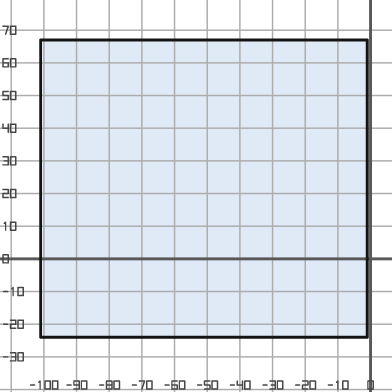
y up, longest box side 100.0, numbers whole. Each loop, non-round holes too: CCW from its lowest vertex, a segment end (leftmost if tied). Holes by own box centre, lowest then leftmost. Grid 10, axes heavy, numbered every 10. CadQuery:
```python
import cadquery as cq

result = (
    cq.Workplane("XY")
    .moveTo(-101.0, -24.0)
    .lineTo(-1.0, -24.0)
    .lineTo(-1.0, 67.0)
    .lineTo(-101.0, 67.0)
    .close()
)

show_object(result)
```